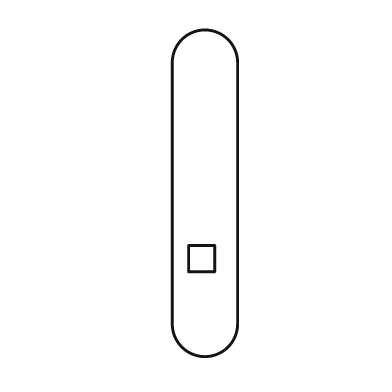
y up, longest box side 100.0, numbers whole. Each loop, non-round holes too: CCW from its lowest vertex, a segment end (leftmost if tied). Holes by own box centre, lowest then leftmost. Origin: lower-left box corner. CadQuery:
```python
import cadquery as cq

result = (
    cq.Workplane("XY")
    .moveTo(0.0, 10.0)
    .threePointArc((10.0, 0.0), (20.0, 10.0))
    .lineTo(20.0, 90.0)
    .threePointArc((10.0, 100.0), (0.0, 90.0))
    .close()
    .moveTo(5.0, 26.0)
    .lineTo(13.0, 26.0)
    .lineTo(13.0, 34.0)
    .lineTo(5.0, 34.0)
    .close()
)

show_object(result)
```